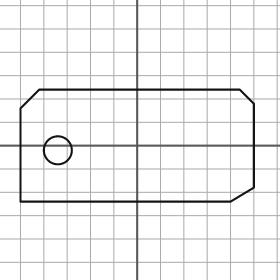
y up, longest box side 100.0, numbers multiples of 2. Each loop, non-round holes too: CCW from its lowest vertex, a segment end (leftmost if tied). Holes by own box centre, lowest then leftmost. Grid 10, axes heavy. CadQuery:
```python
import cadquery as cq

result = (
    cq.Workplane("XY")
    .moveTo(-50.0, -24.0)
    .lineTo(40.0, -24.0)
    .lineTo(50.0, -18.0)
    .lineTo(50.0, 18.0)
    .lineTo(44.0, 24.0)
    .lineTo(-42.0, 24.0)
    .lineTo(-50.0, 16.0)
    .close()
    .moveTo(-34.0, -2.0)
    .circle(6.0)
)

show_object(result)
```